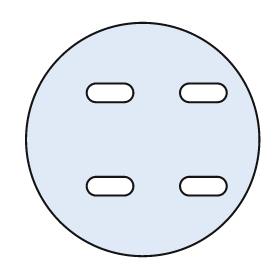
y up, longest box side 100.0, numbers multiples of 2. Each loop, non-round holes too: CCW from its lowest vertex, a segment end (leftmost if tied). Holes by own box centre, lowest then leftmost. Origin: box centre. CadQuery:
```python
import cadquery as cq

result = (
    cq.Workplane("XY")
    .moveTo(0.0, 0.0)
    .circle(50.0)
    .moveTo(-20.0, -24.0)
    .lineTo(-8.0, -24.0)
    .threePointArc((-4.0, -20.0), (-8.0, -16.0))
    .lineTo(-20.0, -16.0)
    .threePointArc((-24.0, -20.0), (-20.0, -24.0))
    .close()
    .moveTo(20.0, -24.0)
    .lineTo(32.0, -24.0)
    .threePointArc((36.0, -20.0), (32.0, -16.0))
    .lineTo(20.0, -16.0)
    .threePointArc((16.0, -20.0), (20.0, -24.0))
    .close()
    .moveTo(-20.0, 16.0)
    .lineTo(-8.0, 16.0)
    .threePointArc((-4.0, 20.0), (-8.0, 24.0))
    .lineTo(-20.0, 24.0)
    .threePointArc((-24.0, 20.0), (-20.0, 16.0))
    .close()
    .moveTo(20.0, 16.0)
    .lineTo(32.0, 16.0)
    .threePointArc((36.0, 20.0), (32.0, 24.0))
    .lineTo(20.0, 24.0)
    .threePointArc((16.0, 20.0), (20.0, 16.0))
    .close()
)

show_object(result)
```